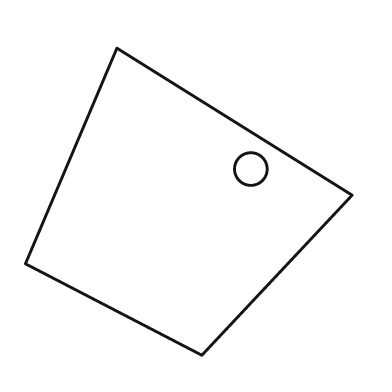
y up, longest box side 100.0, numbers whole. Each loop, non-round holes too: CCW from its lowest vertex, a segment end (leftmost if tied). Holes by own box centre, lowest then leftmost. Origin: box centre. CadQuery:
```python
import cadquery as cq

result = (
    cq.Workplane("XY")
    .moveTo(4.0, -47.0)
    .lineTo(50.0, 2.0)
    .lineTo(-22.0, 47.0)
    .lineTo(-50.0, -19.0)
    .close()
    .moveTo(19.0, 10.0)
    .circle(5.0)
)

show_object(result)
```